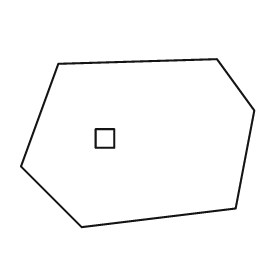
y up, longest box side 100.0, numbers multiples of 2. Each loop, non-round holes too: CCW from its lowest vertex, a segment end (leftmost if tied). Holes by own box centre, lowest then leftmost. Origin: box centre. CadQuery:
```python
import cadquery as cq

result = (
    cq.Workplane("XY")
    .moveTo(-24.0, -36.0)
    .lineTo(42.0, -28.0)
    .lineTo(50.0, 14.0)
    .lineTo(34.0, 36.0)
    .lineTo(-34.0, 34.0)
    .lineTo(-50.0, -10.0)
    .close()
    .moveTo(-18.0, -2.0)
    .lineTo(-10.0, -2.0)
    .lineTo(-10.0, 6.0)
    .lineTo(-18.0, 6.0)
    .close()
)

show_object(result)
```